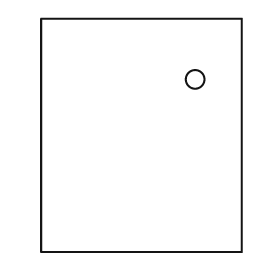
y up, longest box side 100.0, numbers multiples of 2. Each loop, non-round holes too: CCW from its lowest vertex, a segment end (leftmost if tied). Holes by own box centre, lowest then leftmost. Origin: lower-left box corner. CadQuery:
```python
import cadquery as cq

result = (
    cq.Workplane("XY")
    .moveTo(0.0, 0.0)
    .lineTo(86.0, 0.0)
    .lineTo(86.0, 100.0)
    .lineTo(0.0, 100.0)
    .close()
    .moveTo(66.0, 74.0)
    .circle(4.0)
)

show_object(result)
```